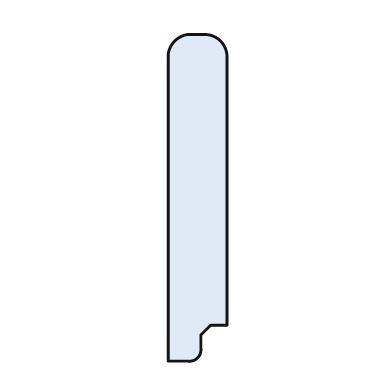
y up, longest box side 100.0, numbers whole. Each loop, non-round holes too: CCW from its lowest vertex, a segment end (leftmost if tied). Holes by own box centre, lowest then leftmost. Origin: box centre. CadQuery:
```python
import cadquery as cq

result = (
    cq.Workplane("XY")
    .moveTo(-9.0, -50.0)
    .lineTo(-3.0, -50.0)
    .threePointArc((0.0, -49.0), (1.0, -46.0))
    .lineTo(1.0, -42.0)
    .lineTo(4.0, -39.0)
    .lineTo(9.0, -39.0)
    .lineTo(9.0, 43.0)
    .threePointArc((7.0, 48.0), (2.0, 50.0))
    .lineTo(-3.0, 50.0)
    .threePointArc((-7.0, 48.0), (-9.0, 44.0))
    .close()
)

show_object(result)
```